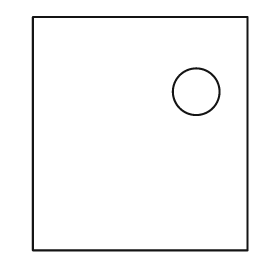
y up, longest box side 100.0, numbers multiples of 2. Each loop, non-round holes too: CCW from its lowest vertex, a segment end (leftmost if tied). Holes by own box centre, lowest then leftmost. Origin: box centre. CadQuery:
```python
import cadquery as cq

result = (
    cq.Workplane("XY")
    .moveTo(-46.0, -50.0)
    .lineTo(46.0, -50.0)
    .lineTo(46.0, 50.0)
    .lineTo(-46.0, 50.0)
    .close()
    .moveTo(24.0, 18.0)
    .circle(10.0)
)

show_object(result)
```